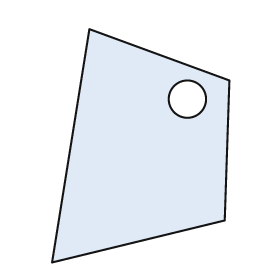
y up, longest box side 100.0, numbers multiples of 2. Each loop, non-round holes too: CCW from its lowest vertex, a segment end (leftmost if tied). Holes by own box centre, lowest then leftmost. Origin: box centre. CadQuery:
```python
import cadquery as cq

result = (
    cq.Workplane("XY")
    .moveTo(-38.0, -50.0)
    .lineTo(36.0, -32.0)
    .lineTo(38.0, 28.0)
    .lineTo(-22.0, 50.0)
    .close()
    .moveTo(20.0, 20.0)
    .circle(8.0)
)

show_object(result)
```